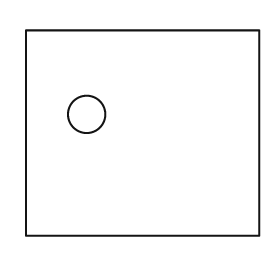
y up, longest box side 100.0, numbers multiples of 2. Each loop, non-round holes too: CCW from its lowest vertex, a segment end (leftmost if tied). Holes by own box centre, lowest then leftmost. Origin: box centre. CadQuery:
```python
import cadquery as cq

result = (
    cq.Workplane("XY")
    .moveTo(-50.0, -44.0)
    .lineTo(50.0, -44.0)
    .lineTo(50.0, 44.0)
    .lineTo(-50.0, 44.0)
    .close()
    .moveTo(-24.0, 8.0)
    .circle(8.0)
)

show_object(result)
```